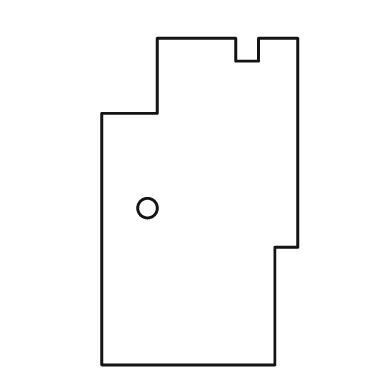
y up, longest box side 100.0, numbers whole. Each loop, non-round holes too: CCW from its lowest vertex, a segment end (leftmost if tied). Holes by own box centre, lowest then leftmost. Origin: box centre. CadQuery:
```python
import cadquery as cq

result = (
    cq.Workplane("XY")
    .moveTo(-30.0, -50.0)
    .lineTo(23.0, -50.0)
    .lineTo(23.0, -14.0)
    .lineTo(30.0, -14.0)
    .lineTo(30.0, 50.0)
    .lineTo(18.0, 50.0)
    .lineTo(18.0, 43.0)
    .lineTo(11.0, 43.0)
    .lineTo(11.0, 50.0)
    .lineTo(-13.0, 50.0)
    .lineTo(-13.0, 27.0)
    .lineTo(-30.0, 27.0)
    .close()
    .moveTo(-16.0, -2.0)
    .circle(3.0)
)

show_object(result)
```